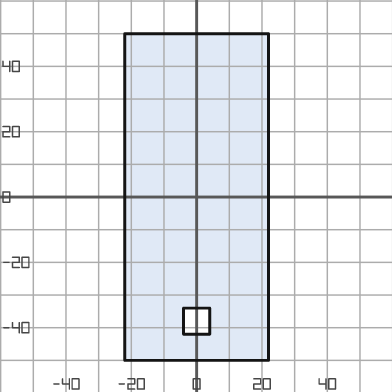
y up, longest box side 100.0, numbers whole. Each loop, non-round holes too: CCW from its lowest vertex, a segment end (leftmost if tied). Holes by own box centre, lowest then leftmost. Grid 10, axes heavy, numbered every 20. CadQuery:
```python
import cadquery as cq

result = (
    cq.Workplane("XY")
    .moveTo(-22.0, -50.0)
    .lineTo(22.0, -50.0)
    .lineTo(22.0, 50.0)
    .lineTo(-22.0, 50.0)
    .close()
    .moveTo(-4.0, -42.0)
    .lineTo(4.0, -42.0)
    .lineTo(4.0, -34.0)
    .lineTo(-4.0, -34.0)
    .close()
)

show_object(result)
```